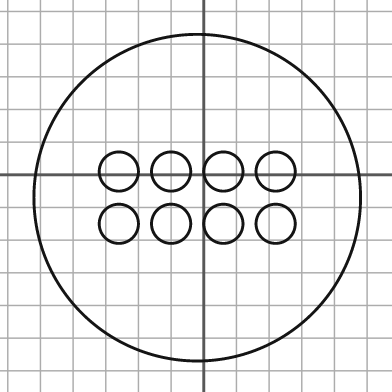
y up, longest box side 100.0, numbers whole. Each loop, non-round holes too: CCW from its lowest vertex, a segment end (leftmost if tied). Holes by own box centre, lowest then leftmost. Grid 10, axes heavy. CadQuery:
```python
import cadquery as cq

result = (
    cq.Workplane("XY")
    .moveTo(-2.0, -7.0)
    .circle(50.0)
    .moveTo(-26.0, -15.0)
    .circle(6.0)
    .moveTo(-10.0, -15.0)
    .circle(6.0)
    .moveTo(6.0, -15.0)
    .circle(6.0)
    .moveTo(22.0, -15.0)
    .circle(6.0)
    .moveTo(-26.0, 1.0)
    .circle(6.0)
    .moveTo(-10.0, 1.0)
    .circle(6.0)
    .moveTo(6.0, 1.0)
    .circle(6.0)
    .moveTo(22.0, 1.0)
    .circle(6.0)
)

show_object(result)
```